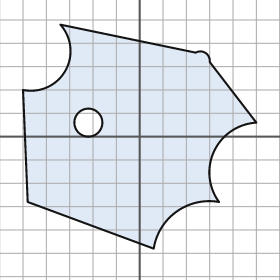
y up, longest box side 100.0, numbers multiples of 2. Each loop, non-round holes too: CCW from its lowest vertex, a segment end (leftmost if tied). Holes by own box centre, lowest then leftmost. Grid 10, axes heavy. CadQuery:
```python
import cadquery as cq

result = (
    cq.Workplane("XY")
    .moveTo(6.0, -48.0)
    .threePointArc((16.0, -32.0), (34.0, -28.0))
    .threePointArc((32.0, -6.0), (50.0, 6.0))
    .lineTo(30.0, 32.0)
    .threePointArc((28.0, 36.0), (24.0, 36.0))
    .lineTo(-34.0, 48.0)
    .threePointArc((-32.0, 28.0), (-50.0, 20.0))
    .lineTo(-48.0, -28.0)
    .close()
    .moveTo(-22.0, 6.0)
    .circle(6.0)
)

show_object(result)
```